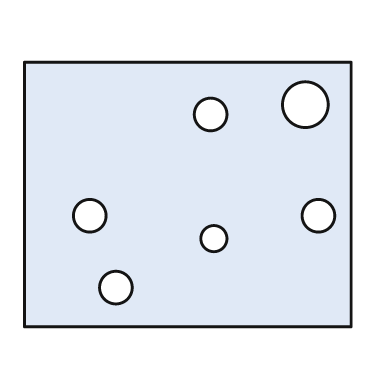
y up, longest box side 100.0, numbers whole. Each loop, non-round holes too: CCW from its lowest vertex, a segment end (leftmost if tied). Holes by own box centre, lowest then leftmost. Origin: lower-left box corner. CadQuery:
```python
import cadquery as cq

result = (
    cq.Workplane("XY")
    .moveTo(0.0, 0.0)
    .lineTo(100.0, 0.0)
    .lineTo(100.0, 81.0)
    .lineTo(0.0, 81.0)
    .close()
    .moveTo(28.0, 12.0)
    .circle(5.0)
    .moveTo(58.0, 27.0)
    .circle(4.0)
    .moveTo(20.0, 34.0)
    .circle(5.0)
    .moveTo(90.0, 34.0)
    .circle(5.0)
    .moveTo(57.0, 65.0)
    .circle(5.0)
    .moveTo(86.0, 68.0)
    .circle(7.0)
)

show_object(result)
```